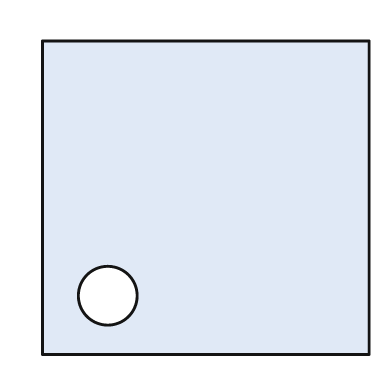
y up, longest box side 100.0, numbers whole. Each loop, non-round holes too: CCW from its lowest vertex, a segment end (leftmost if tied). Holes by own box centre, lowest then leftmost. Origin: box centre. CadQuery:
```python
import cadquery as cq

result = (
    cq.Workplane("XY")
    .moveTo(-50.0, -48.0)
    .lineTo(50.0, -48.0)
    .lineTo(50.0, 48.0)
    .lineTo(-50.0, 48.0)
    .close()
    .moveTo(-30.0, -30.0)
    .circle(9.0)
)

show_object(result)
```